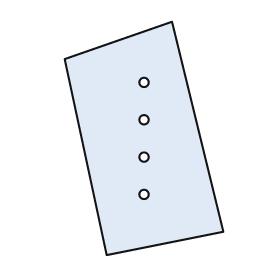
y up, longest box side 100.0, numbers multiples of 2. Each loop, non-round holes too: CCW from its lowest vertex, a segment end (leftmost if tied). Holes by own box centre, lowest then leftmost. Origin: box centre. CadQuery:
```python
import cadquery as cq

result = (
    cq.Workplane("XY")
    .moveTo(-16.0, -50.0)
    .lineTo(34.0, -40.0)
    .lineTo(12.0, 50.0)
    .lineTo(-34.0, 34.0)
    .close()
    .moveTo(0.0, -24.0)
    .circle(2.0)
    .moveTo(0.0, -8.0)
    .circle(2.0)
    .moveTo(0.0, 8.0)
    .circle(2.0)
    .moveTo(0.0, 24.0)
    .circle(2.0)
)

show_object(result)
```